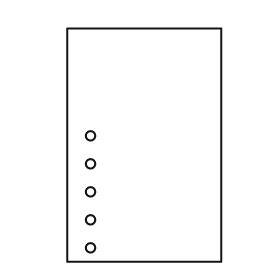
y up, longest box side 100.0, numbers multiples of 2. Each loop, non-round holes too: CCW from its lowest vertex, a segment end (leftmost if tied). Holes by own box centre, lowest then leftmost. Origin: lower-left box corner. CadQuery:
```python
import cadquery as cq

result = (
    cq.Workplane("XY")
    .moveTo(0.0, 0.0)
    .lineTo(66.0, 0.0)
    .lineTo(66.0, 100.0)
    .lineTo(0.0, 100.0)
    .close()
    .moveTo(10.0, 6.0)
    .circle(2.0)
    .moveTo(10.0, 18.0)
    .circle(2.0)
    .moveTo(10.0, 30.0)
    .circle(2.0)
    .moveTo(10.0, 42.0)
    .circle(2.0)
    .moveTo(10.0, 54.0)
    .circle(2.0)
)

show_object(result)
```